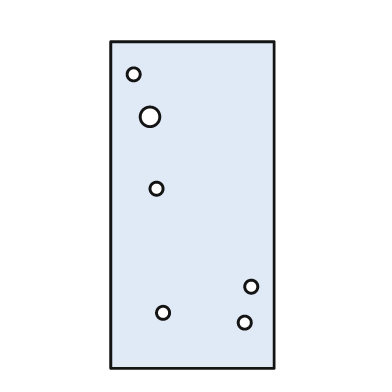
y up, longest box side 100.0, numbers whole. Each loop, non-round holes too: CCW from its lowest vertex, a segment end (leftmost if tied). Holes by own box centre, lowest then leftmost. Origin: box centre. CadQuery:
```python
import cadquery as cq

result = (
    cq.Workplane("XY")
    .moveTo(-25.0, -50.0)
    .lineTo(25.0, -50.0)
    .lineTo(25.0, 50.0)
    .lineTo(-25.0, 50.0)
    .close()
    .moveTo(16.0, -36.0)
    .circle(2.0)
    .moveTo(-9.0, -33.0)
    .circle(2.0)
    .moveTo(18.0, -25.0)
    .circle(2.0)
    .moveTo(-11.0, 5.0)
    .circle(2.0)
    .moveTo(-13.0, 27.0)
    .circle(3.0)
    .moveTo(-18.0, 40.0)
    .circle(2.0)
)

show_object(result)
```